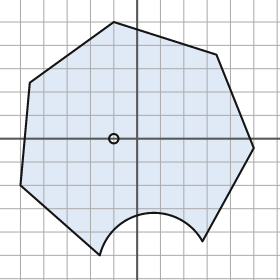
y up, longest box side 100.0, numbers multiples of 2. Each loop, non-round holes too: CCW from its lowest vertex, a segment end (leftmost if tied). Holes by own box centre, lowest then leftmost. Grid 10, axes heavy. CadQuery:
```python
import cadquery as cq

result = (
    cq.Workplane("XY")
    .moveTo(-16.0, -50.0)
    .threePointArc((4.0, -32.0), (28.0, -44.0))
    .lineTo(50.0, -4.0)
    .lineTo(34.0, 36.0)
    .lineTo(-10.0, 50.0)
    .lineTo(-46.0, 24.0)
    .lineTo(-50.0, -20.0)
    .close()
    .moveTo(-10.0, 0.0)
    .circle(2.0)
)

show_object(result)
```